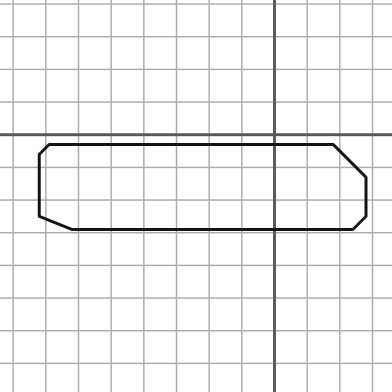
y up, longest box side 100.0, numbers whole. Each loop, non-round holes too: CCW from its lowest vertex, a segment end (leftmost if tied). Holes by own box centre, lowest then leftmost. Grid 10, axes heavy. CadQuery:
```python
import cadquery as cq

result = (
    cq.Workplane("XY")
    .moveTo(-62.0, -29.0)
    .lineTo(24.0, -29.0)
    .lineTo(28.0, -25.0)
    .lineTo(28.0, -13.0)
    .lineTo(18.0, -3.0)
    .lineTo(-69.0, -3.0)
    .lineTo(-72.0, -6.0)
    .lineTo(-72.0, -25.0)
    .close()
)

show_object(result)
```